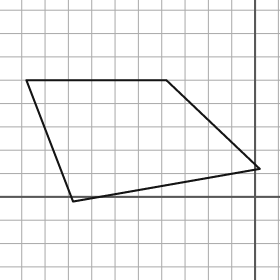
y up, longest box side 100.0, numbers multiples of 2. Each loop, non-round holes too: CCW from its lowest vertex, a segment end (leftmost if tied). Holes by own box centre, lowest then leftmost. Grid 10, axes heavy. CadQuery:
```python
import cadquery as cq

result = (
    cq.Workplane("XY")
    .moveTo(-78.0, -2.0)
    .lineTo(2.0, 12.0)
    .lineTo(-38.0, 50.0)
    .lineTo(-98.0, 50.0)
    .close()
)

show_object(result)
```